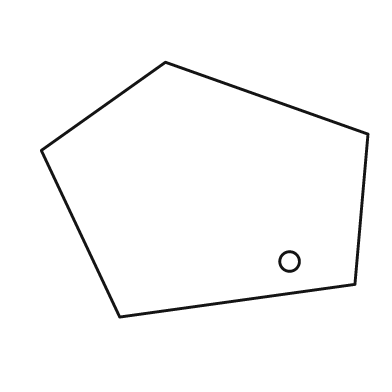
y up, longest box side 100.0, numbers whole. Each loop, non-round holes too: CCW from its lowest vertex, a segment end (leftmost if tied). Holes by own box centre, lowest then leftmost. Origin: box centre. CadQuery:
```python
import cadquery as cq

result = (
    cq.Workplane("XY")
    .moveTo(-26.0, -39.0)
    .lineTo(46.0, -29.0)
    .lineTo(50.0, 17.0)
    .lineTo(-12.0, 39.0)
    .lineTo(-50.0, 12.0)
    .close()
    .moveTo(26.0, -22.0)
    .circle(3.0)
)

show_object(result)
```